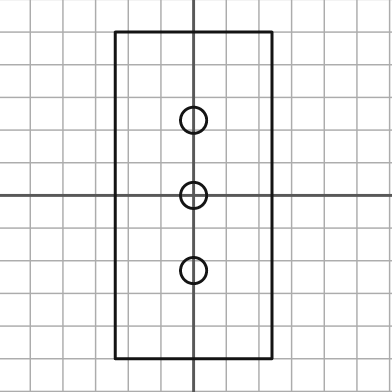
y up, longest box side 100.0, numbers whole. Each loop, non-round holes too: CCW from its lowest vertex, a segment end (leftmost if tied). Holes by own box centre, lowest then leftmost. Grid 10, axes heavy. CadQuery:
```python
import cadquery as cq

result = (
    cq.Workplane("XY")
    .moveTo(-24.0, -50.0)
    .lineTo(24.0, -50.0)
    .lineTo(24.0, 50.0)
    .lineTo(-24.0, 50.0)
    .close()
    .moveTo(0.0, -23.0)
    .circle(4.0)
    .moveTo(0.0, 0.0)
    .circle(4.0)
    .moveTo(0.0, 23.0)
    .circle(4.0)
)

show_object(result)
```